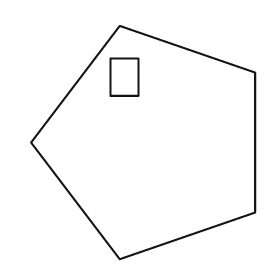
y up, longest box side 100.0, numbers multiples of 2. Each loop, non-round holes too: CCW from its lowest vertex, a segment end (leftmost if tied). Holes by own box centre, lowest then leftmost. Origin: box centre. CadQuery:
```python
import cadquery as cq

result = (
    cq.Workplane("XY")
    .moveTo(-10.0, -50.0)
    .lineTo(48.0, -30.0)
    .lineTo(48.0, 30.0)
    .lineTo(-10.0, 50.0)
    .lineTo(-48.0, 0.0)
    .close()
    .moveTo(-14.0, 20.0)
    .lineTo(-2.0, 20.0)
    .lineTo(-2.0, 36.0)
    .lineTo(-14.0, 36.0)
    .close()
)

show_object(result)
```